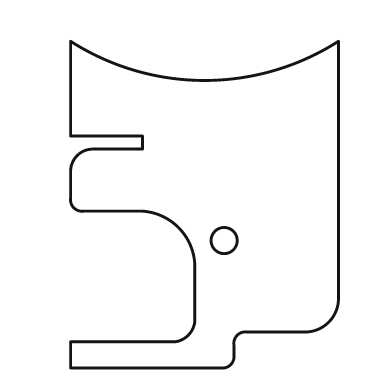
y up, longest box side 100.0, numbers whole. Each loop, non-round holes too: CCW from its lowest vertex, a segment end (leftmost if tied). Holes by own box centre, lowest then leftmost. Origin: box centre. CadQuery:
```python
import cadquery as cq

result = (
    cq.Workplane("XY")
    .moveTo(-41.0, -50.0)
    .lineTo(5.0, -50.0)
    .threePointArc((8.0, -49.0), (9.0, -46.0))
    .lineTo(9.0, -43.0)
    .threePointArc((10.0, -40.0), (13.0, -39.0))
    .lineTo(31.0, -39.0)
    .threePointArc((38.0, -36.0), (41.0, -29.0))
    .lineTo(41.0, 50.0)
    .threePointArc((0.0, 38.0), (-41.0, 50.0))
    .lineTo(-41.0, 21.0)
    .lineTo(-19.0, 21.0)
    .lineTo(-19.0, 17.0)
    .lineTo(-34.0, 17.0)
    .threePointArc((-39.0, 15.0), (-41.0, 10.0))
    .lineTo(-41.0, 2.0)
    .threePointArc((-40.0, -1.0), (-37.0, -2.0))
    .lineTo(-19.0, -2.0)
    .threePointArc((-8.0, -7.0), (-3.0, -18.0))
    .lineTo(-3.0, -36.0)
    .threePointArc((-5.0, -40.0), (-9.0, -42.0))
    .lineTo(-41.0, -42.0)
    .close()
    .moveTo(6.0, -11.0)
    .circle(4.0)
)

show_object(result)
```